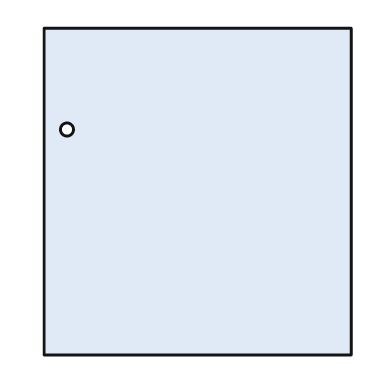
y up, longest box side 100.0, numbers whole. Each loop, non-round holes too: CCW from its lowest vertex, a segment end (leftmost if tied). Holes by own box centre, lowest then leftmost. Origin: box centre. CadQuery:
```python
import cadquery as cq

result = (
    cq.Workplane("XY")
    .moveTo(-47.0, -50.0)
    .lineTo(47.0, -50.0)
    .lineTo(47.0, 50.0)
    .lineTo(-47.0, 50.0)
    .close()
    .moveTo(-40.0, 19.0)
    .circle(2.0)
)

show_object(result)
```